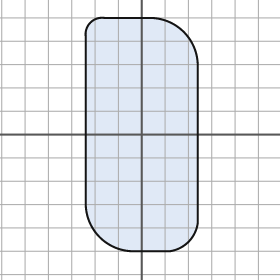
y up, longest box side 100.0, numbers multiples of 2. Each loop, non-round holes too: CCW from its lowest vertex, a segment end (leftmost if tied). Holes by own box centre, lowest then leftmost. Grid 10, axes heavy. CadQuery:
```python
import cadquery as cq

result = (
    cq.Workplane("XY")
    .moveTo(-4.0, -50.0)
    .lineTo(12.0, -50.0)
    .threePointArc((20.0, -46.0), (24.0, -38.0))
    .lineTo(24.0, 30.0)
    .threePointArc((18.0, 44.0), (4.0, 50.0))
    .lineTo(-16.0, 50.0)
    .threePointArc((-22.0, 48.0), (-24.0, 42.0))
    .lineTo(-24.0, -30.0)
    .threePointArc((-18.0, -44.0), (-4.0, -50.0))
    .close()
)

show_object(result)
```